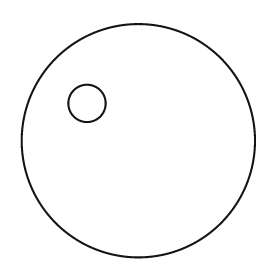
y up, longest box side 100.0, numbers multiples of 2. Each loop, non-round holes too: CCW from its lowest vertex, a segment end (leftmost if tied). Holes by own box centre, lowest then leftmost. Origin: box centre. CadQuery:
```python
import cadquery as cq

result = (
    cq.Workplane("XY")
    .moveTo(0.0, 0.0)
    .circle(50.0)
    .moveTo(-22.0, 16.0)
    .circle(8.0)
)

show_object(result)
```